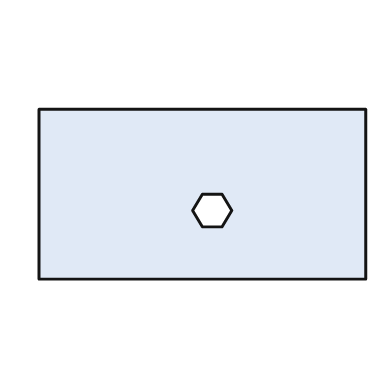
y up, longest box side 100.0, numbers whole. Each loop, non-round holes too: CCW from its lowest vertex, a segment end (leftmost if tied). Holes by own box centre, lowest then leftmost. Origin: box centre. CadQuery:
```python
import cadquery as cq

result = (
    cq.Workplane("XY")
    .moveTo(-50.0, -26.0)
    .lineTo(50.0, -26.0)
    .lineTo(50.0, 26.0)
    .lineTo(-50.0, 26.0)
    .close()
    .moveTo(0.0, -10.0)
    .lineTo(6.0, -10.0)
    .lineTo(9.0, -5.0)
    .lineTo(6.0, 0.0)
    .lineTo(0.0, 0.0)
    .lineTo(-3.0, -5.0)
    .close()
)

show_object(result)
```